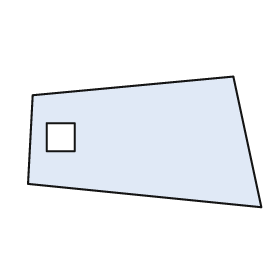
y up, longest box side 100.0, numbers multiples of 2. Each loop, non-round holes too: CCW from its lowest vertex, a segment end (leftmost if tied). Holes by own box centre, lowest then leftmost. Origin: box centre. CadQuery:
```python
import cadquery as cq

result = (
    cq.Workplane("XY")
    .moveTo(50.0, -28.0)
    .lineTo(38.0, 28.0)
    .lineTo(-48.0, 20.0)
    .lineTo(-50.0, -18.0)
    .close()
    .moveTo(-42.0, -4.0)
    .lineTo(-30.0, -4.0)
    .lineTo(-30.0, 8.0)
    .lineTo(-42.0, 8.0)
    .close()
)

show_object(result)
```